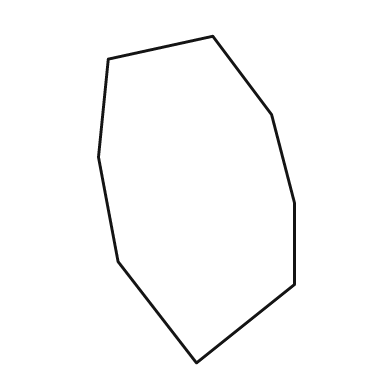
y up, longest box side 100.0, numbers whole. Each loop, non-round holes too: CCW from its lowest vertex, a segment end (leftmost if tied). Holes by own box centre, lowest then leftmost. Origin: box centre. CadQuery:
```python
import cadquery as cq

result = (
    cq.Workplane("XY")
    .moveTo(0.0, -50.0)
    .lineTo(30.0, -26.0)
    .lineTo(30.0, -1.0)
    .lineTo(23.0, 26.0)
    .lineTo(5.0, 50.0)
    .lineTo(-27.0, 43.0)
    .lineTo(-30.0, 13.0)
    .lineTo(-24.0, -19.0)
    .close()
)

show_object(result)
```